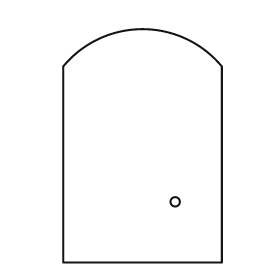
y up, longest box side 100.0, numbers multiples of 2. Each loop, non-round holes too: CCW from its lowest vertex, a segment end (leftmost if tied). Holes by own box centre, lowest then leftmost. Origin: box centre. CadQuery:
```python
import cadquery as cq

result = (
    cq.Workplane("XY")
    .moveTo(-34.0, -50.0)
    .lineTo(34.0, -50.0)
    .lineTo(34.0, 34.0)
    .threePointArc((0.0, 50.0), (-34.0, 34.0))
    .close()
    .moveTo(14.0, -24.0)
    .circle(2.0)
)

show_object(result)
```